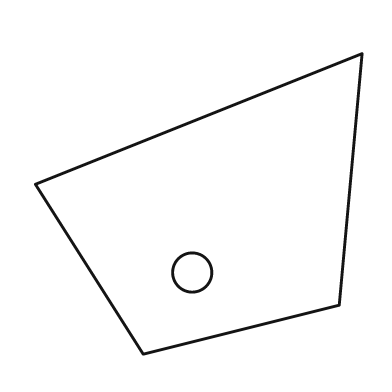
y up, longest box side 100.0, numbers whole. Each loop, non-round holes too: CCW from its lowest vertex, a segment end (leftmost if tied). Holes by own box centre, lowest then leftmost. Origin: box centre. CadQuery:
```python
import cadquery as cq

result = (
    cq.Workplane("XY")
    .moveTo(-17.0, -46.0)
    .lineTo(43.0, -31.0)
    .lineTo(50.0, 46.0)
    .lineTo(-50.0, 6.0)
    .close()
    .moveTo(-2.0, -21.0)
    .circle(6.0)
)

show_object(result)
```